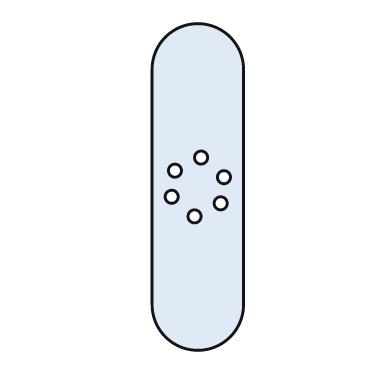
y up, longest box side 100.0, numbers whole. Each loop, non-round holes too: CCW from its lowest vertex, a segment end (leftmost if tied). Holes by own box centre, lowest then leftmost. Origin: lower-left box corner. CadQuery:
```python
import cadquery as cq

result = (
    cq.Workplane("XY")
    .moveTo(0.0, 14.0)
    .threePointArc((14.0, 0.0), (28.0, 14.0))
    .lineTo(28.0, 86.0)
    .threePointArc((14.0, 100.0), (0.0, 86.0))
    .close()
    .moveTo(13.0, 41.0)
    .circle(2.0)
    .moveTo(21.0, 45.0)
    .circle(2.0)
    .moveTo(6.0, 47.0)
    .circle(2.0)
    .moveTo(22.0, 53.0)
    .circle(2.0)
    .moveTo(7.0, 55.0)
    .circle(2.0)
    .moveTo(15.0, 59.0)
    .circle(2.0)
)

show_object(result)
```